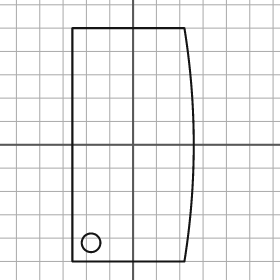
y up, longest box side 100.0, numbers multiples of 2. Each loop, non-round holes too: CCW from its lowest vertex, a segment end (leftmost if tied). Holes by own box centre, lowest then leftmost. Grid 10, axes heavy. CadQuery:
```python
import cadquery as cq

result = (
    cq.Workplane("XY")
    .moveTo(-26.0, -50.0)
    .lineTo(22.0, -50.0)
    .threePointArc((26.0, 0.0), (22.0, 50.0))
    .lineTo(-26.0, 50.0)
    .close()
    .moveTo(-18.0, -42.0)
    .circle(4.0)
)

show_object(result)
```